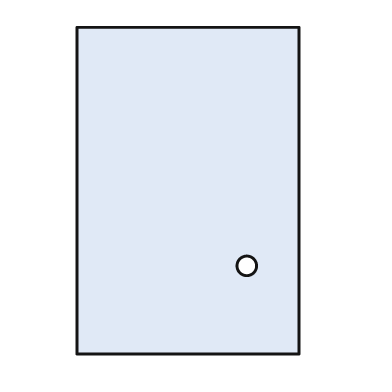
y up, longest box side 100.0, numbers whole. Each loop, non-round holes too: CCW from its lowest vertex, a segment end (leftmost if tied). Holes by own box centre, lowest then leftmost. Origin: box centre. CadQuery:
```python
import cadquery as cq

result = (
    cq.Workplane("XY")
    .moveTo(-34.0, -50.0)
    .lineTo(34.0, -50.0)
    .lineTo(34.0, 50.0)
    .lineTo(-34.0, 50.0)
    .close()
    .moveTo(18.0, -23.0)
    .circle(3.0)
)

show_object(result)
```